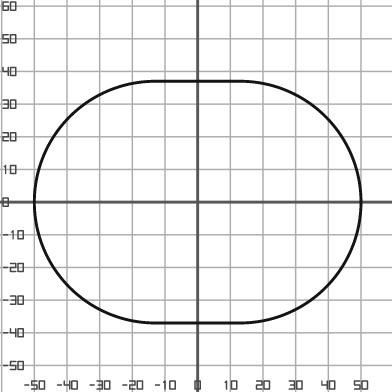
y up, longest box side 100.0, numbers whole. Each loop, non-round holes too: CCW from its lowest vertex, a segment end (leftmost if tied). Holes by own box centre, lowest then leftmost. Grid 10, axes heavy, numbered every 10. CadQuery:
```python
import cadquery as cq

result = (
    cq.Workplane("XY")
    .moveTo(-13.0, -37.0)
    .lineTo(13.0, -37.0)
    .threePointArc((50.0, 0.0), (13.0, 37.0))
    .lineTo(-13.0, 37.0)
    .threePointArc((-50.0, 0.0), (-13.0, -37.0))
    .close()
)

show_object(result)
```